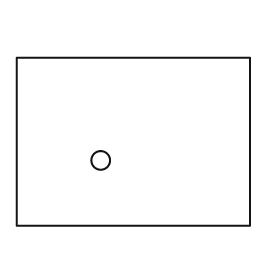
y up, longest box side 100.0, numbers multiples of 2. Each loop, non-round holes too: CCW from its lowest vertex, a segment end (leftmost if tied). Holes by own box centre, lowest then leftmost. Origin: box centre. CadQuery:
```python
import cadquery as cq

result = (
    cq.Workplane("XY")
    .moveTo(-50.0, -36.0)
    .lineTo(50.0, -36.0)
    .lineTo(50.0, 36.0)
    .lineTo(-50.0, 36.0)
    .close()
    .moveTo(-14.0, -8.0)
    .circle(4.0)
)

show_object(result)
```